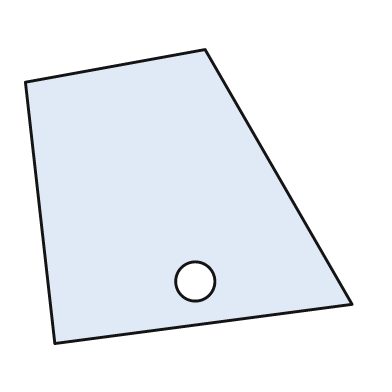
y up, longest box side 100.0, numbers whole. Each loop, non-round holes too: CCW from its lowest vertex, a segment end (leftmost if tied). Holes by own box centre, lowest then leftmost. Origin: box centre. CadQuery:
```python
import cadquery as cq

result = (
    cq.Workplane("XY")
    .moveTo(-41.0, -45.0)
    .lineTo(50.0, -33.0)
    .lineTo(5.0, 45.0)
    .lineTo(-50.0, 35.0)
    .close()
    .moveTo(2.0, -26.0)
    .circle(6.0)
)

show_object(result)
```